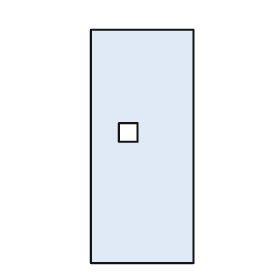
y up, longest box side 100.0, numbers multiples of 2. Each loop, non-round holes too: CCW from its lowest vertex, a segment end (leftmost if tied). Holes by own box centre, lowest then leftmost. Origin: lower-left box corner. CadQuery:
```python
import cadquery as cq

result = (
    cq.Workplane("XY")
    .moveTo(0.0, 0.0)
    .lineTo(44.0, 0.0)
    .lineTo(44.0, 100.0)
    .lineTo(0.0, 100.0)
    .close()
    .moveTo(12.0, 52.0)
    .lineTo(20.0, 52.0)
    .lineTo(20.0, 60.0)
    .lineTo(12.0, 60.0)
    .close()
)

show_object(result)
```